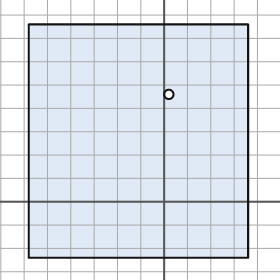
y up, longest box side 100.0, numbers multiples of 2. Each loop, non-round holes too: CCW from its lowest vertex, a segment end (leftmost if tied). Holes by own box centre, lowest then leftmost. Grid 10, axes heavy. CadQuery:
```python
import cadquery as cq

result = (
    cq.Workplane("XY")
    .moveTo(-58.0, -24.0)
    .lineTo(36.0, -24.0)
    .lineTo(36.0, 76.0)
    .lineTo(-58.0, 76.0)
    .close()
    .moveTo(2.0, 46.0)
    .circle(2.0)
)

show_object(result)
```